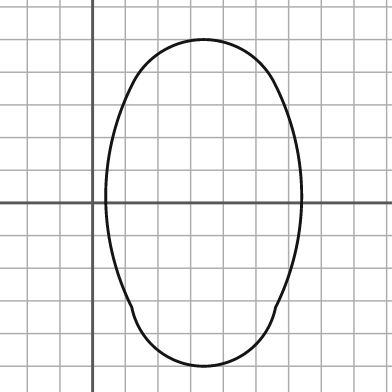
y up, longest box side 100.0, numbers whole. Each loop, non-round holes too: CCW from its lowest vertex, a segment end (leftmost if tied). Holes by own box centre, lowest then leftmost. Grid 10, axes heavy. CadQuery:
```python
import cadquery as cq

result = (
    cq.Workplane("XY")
    .moveTo(12.0, -32.0)
    .threePointArc((34.0, -50.0), (56.0, -32.0))
    .threePointArc((64.0, 2.0), (56.0, 36.0))
    .threePointArc((34.0, 50.0), (12.0, 36.0))
    .threePointArc((4.0, 2.0), (12.0, -32.0))
    .close()
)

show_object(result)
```